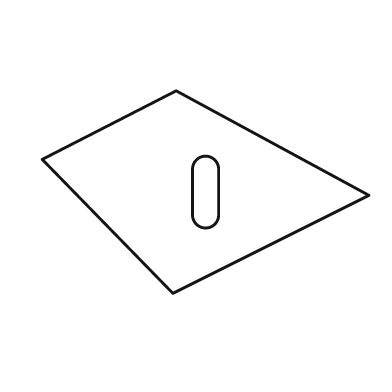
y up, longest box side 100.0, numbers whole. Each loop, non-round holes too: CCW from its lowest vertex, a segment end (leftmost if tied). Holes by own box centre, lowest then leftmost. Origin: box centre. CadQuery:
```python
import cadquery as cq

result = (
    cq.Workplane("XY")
    .moveTo(-10.0, -31.0)
    .lineTo(50.0, -1.0)
    .lineTo(-9.0, 31.0)
    .lineTo(-50.0, 10.0)
    .close()
    .moveTo(-4.0, -7.0)
    .threePointArc((0.0, -11.0), (4.0, -7.0))
    .lineTo(4.0, 7.0)
    .threePointArc((0.0, 11.0), (-4.0, 7.0))
    .close()
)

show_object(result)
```